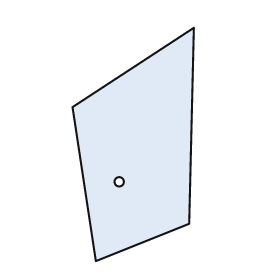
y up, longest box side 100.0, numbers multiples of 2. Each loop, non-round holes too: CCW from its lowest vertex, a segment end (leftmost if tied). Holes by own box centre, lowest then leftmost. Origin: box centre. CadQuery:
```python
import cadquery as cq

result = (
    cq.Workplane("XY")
    .moveTo(-16.0, -50.0)
    .lineTo(24.0, -34.0)
    .lineTo(26.0, 50.0)
    .lineTo(-26.0, 16.0)
    .close()
    .moveTo(-6.0, -16.0)
    .circle(2.0)
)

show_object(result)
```